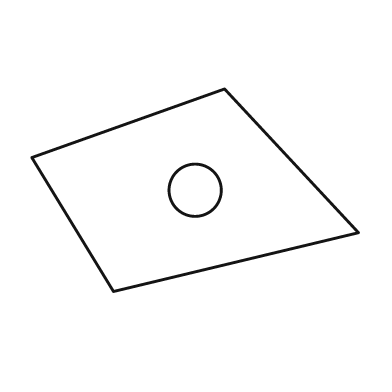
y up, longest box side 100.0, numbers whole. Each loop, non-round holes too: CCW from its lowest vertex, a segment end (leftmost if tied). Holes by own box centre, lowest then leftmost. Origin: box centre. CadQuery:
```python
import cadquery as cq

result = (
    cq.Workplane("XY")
    .moveTo(-25.0, -31.0)
    .lineTo(50.0, -13.0)
    .lineTo(9.0, 31.0)
    .lineTo(-50.0, 10.0)
    .close()
    .moveTo(0.0, 0.0)
    .circle(8.0)
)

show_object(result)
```